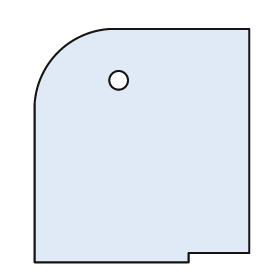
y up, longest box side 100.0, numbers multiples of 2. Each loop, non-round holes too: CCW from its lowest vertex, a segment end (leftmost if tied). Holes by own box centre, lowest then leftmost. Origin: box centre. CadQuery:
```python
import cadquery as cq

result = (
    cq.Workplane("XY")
    .moveTo(-46.0, -50.0)
    .lineTo(20.0, -50.0)
    .lineTo(20.0, -46.0)
    .lineTo(46.0, -46.0)
    .lineTo(46.0, 50.0)
    .lineTo(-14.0, 50.0)
    .threePointArc((-36.0, 40.0), (-46.0, 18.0))
    .close()
    .moveTo(-10.0, 28.0)
    .circle(4.0)
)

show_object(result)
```